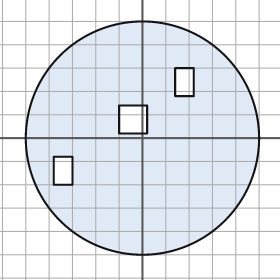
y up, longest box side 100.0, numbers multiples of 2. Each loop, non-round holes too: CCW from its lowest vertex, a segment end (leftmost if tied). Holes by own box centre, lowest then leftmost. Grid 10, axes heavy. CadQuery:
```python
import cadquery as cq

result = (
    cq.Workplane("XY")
    .moveTo(0.0, 0.0)
    .circle(50.0)
    .moveTo(-38.0, -20.0)
    .lineTo(-30.0, -20.0)
    .lineTo(-30.0, -8.0)
    .lineTo(-38.0, -8.0)
    .close()
    .moveTo(-10.0, 2.0)
    .lineTo(2.0, 2.0)
    .lineTo(2.0, 14.0)
    .lineTo(-10.0, 14.0)
    .close()
    .moveTo(14.0, 18.0)
    .lineTo(22.0, 18.0)
    .lineTo(22.0, 30.0)
    .lineTo(14.0, 30.0)
    .close()
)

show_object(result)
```